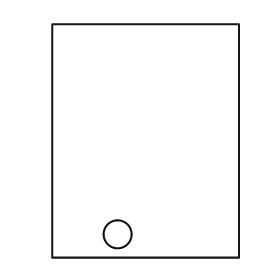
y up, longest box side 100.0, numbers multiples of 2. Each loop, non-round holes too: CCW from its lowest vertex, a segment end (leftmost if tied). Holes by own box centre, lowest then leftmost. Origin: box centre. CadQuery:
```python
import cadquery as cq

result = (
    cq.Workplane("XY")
    .moveTo(-40.0, -50.0)
    .lineTo(40.0, -50.0)
    .lineTo(40.0, 50.0)
    .lineTo(-40.0, 50.0)
    .close()
    .moveTo(-12.0, -40.0)
    .circle(6.0)
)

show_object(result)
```